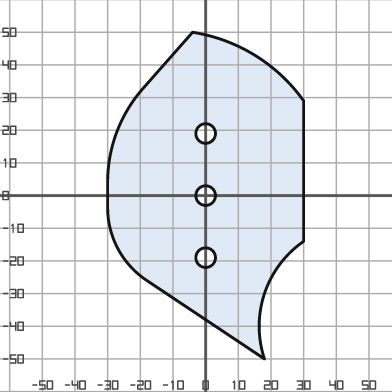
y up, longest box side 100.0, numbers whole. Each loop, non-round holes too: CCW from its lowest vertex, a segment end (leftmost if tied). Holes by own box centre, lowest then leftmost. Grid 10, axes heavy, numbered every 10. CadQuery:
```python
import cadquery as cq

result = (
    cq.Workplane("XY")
    .moveTo(18.0, -50.0)
    .threePointArc((18.0, -30.0), (30.0, -14.0))
    .lineTo(30.0, 29.0)
    .threePointArc((15.0, 43.0), (-4.0, 50.0))
    .lineTo(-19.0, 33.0)
    .threePointArc((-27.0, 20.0), (-30.0, 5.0))
    .lineTo(-30.0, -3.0)
    .threePointArc((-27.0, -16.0), (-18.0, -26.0))
    .close()
    .moveTo(0.0, -19.0)
    .circle(3.0)
    .moveTo(0.0, 0.0)
    .circle(3.0)
    .moveTo(0.0, 19.0)
    .circle(3.0)
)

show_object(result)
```